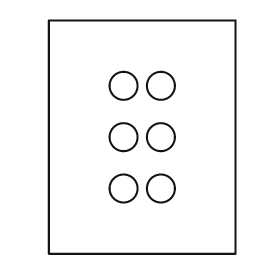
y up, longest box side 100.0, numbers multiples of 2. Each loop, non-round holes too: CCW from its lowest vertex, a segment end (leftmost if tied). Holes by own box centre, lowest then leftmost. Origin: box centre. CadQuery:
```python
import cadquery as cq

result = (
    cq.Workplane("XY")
    .moveTo(-40.0, -50.0)
    .lineTo(40.0, -50.0)
    .lineTo(40.0, 50.0)
    .lineTo(-40.0, 50.0)
    .close()
    .moveTo(-8.0, -22.0)
    .circle(6.0)
    .moveTo(8.0, -22.0)
    .circle(6.0)
    .moveTo(-8.0, 0.0)
    .circle(6.0)
    .moveTo(8.0, 0.0)
    .circle(6.0)
    .moveTo(-8.0, 22.0)
    .circle(6.0)
    .moveTo(8.0, 22.0)
    .circle(6.0)
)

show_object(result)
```